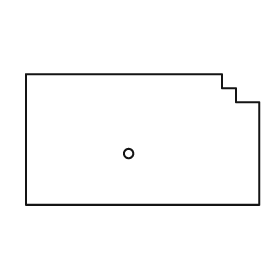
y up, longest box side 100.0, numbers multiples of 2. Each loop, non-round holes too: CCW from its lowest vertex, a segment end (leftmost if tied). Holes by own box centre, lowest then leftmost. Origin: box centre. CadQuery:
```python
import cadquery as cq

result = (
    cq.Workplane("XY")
    .moveTo(-50.0, -28.0)
    .lineTo(50.0, -28.0)
    .lineTo(50.0, 16.0)
    .lineTo(40.0, 16.0)
    .lineTo(40.0, 22.0)
    .lineTo(34.0, 22.0)
    .lineTo(34.0, 28.0)
    .lineTo(-50.0, 28.0)
    .close()
    .moveTo(-6.0, -6.0)
    .circle(2.0)
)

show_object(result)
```